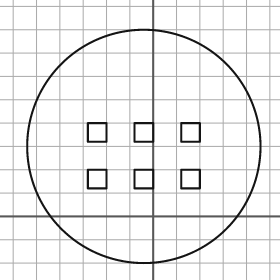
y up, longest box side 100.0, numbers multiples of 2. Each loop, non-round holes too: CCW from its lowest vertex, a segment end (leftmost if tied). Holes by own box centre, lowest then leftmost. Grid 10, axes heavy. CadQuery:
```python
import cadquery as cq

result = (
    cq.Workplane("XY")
    .moveTo(-4.0, 30.0)
    .circle(50.0)
    .moveTo(-28.0, 12.0)
    .lineTo(-20.0, 12.0)
    .lineTo(-20.0, 20.0)
    .lineTo(-28.0, 20.0)
    .close()
    .moveTo(-8.0, 12.0)
    .lineTo(0.0, 12.0)
    .lineTo(0.0, 20.0)
    .lineTo(-8.0, 20.0)
    .close()
    .moveTo(12.0, 12.0)
    .lineTo(20.0, 12.0)
    .lineTo(20.0, 20.0)
    .lineTo(12.0, 20.0)
    .close()
    .moveTo(-28.0, 32.0)
    .lineTo(-20.0, 32.0)
    .lineTo(-20.0, 40.0)
    .lineTo(-28.0, 40.0)
    .close()
    .moveTo(-8.0, 32.0)
    .lineTo(0.0, 32.0)
    .lineTo(0.0, 40.0)
    .lineTo(-8.0, 40.0)
    .close()
    .moveTo(12.0, 32.0)
    .lineTo(20.0, 32.0)
    .lineTo(20.0, 40.0)
    .lineTo(12.0, 40.0)
    .close()
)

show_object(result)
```